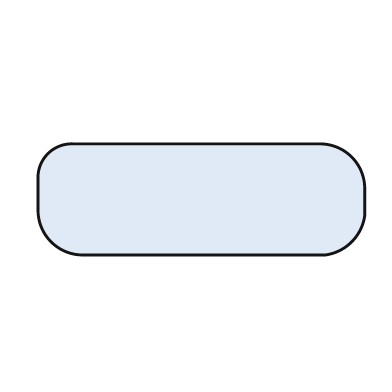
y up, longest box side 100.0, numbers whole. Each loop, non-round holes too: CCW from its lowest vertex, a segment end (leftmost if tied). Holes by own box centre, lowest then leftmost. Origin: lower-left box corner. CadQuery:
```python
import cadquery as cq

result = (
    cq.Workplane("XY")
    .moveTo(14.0, 0.0)
    .lineTo(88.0, 0.0)
    .threePointArc((96.0, 4.0), (100.0, 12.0))
    .lineTo(100.0, 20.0)
    .threePointArc((96.0, 30.0), (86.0, 34.0))
    .lineTo(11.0, 34.0)
    .threePointArc((3.0, 31.0), (0.0, 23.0))
    .lineTo(0.0, 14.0)
    .threePointArc((4.0, 4.0), (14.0, 0.0))
    .close()
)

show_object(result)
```